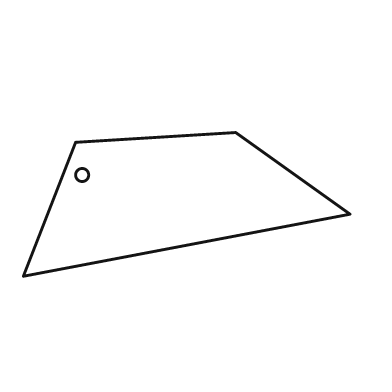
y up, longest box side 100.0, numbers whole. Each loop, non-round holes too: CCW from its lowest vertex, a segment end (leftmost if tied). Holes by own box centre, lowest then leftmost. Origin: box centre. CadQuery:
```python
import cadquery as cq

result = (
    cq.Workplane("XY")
    .moveTo(-50.0, -22.0)
    .lineTo(50.0, -3.0)
    .lineTo(15.0, 22.0)
    .lineTo(-34.0, 19.0)
    .close()
    .moveTo(-32.0, 9.0)
    .circle(2.0)
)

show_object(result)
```